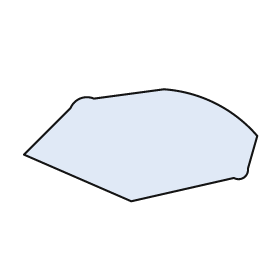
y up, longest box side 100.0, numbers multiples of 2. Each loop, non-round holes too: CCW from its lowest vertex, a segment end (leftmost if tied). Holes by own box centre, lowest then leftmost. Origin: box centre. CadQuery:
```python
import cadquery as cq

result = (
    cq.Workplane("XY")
    .moveTo(-4.0, -24.0)
    .lineTo(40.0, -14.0)
    .threePointArc((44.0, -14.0), (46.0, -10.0))
    .lineTo(50.0, 4.0)
    .threePointArc((32.0, 18.0), (10.0, 24.0))
    .lineTo(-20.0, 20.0)
    .threePointArc((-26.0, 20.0), (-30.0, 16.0))
    .lineTo(-50.0, -4.0)
    .close()
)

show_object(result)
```